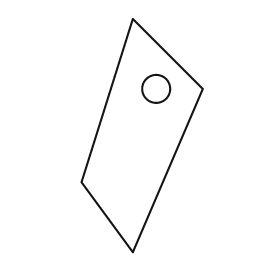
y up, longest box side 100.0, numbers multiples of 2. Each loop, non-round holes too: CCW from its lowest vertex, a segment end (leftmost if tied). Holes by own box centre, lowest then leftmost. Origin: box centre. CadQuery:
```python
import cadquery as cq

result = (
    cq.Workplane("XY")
    .moveTo(-4.0, -50.0)
    .lineTo(26.0, 20.0)
    .lineTo(-4.0, 50.0)
    .lineTo(-26.0, -20.0)
    .close()
    .moveTo(6.0, 20.0)
    .circle(6.0)
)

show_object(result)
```